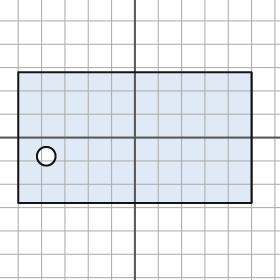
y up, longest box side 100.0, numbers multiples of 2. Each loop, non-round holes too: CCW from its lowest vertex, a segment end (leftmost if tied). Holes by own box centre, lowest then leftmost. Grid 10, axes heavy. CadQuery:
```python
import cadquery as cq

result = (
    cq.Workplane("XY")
    .moveTo(-50.0, -28.0)
    .lineTo(50.0, -28.0)
    .lineTo(50.0, 28.0)
    .lineTo(-50.0, 28.0)
    .close()
    .moveTo(-38.0, -8.0)
    .circle(4.0)
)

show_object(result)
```